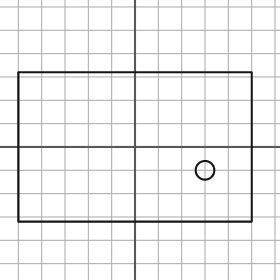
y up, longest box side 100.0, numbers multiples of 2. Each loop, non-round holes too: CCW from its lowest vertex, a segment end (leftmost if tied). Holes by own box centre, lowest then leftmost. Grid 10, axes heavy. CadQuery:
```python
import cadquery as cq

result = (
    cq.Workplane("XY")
    .moveTo(-50.0, -32.0)
    .lineTo(50.0, -32.0)
    .lineTo(50.0, 32.0)
    .lineTo(-50.0, 32.0)
    .close()
    .moveTo(30.0, -10.0)
    .circle(4.0)
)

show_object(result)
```